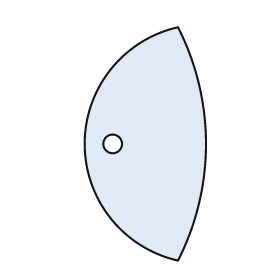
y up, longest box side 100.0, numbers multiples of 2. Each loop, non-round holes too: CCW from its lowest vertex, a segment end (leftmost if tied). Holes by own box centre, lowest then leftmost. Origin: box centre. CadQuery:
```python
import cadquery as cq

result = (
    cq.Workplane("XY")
    .moveTo(14.0, -50.0)
    .threePointArc((26.0, 0.0), (14.0, 50.0))
    .threePointArc((-26.0, 0.0), (14.0, -50.0))
    .close()
    .moveTo(-14.0, 0.0)
    .circle(4.0)
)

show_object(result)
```